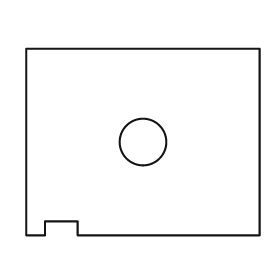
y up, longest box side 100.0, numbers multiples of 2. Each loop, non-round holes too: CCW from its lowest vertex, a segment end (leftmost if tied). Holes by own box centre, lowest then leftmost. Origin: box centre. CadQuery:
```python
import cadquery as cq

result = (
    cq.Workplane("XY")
    .moveTo(-50.0, -40.0)
    .lineTo(-42.0, -40.0)
    .lineTo(-42.0, -34.0)
    .lineTo(-28.0, -34.0)
    .lineTo(-28.0, -40.0)
    .lineTo(50.0, -40.0)
    .lineTo(50.0, 40.0)
    .lineTo(-50.0, 40.0)
    .close()
    .moveTo(0.0, 0.0)
    .circle(10.0)
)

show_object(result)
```